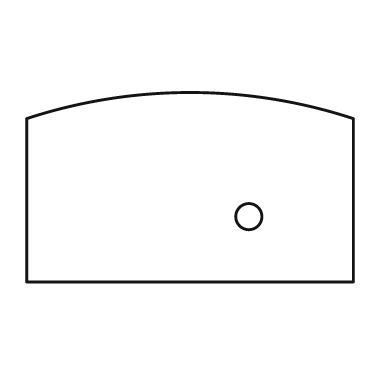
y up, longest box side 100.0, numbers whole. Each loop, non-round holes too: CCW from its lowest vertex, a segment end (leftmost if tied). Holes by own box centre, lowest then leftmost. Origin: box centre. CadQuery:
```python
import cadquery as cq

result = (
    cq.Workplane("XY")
    .moveTo(-50.0, -29.0)
    .lineTo(50.0, -29.0)
    .lineTo(50.0, 21.0)
    .threePointArc((0.0, 29.0), (-50.0, 21.0))
    .close()
    .moveTo(18.0, -9.0)
    .circle(4.0)
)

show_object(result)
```